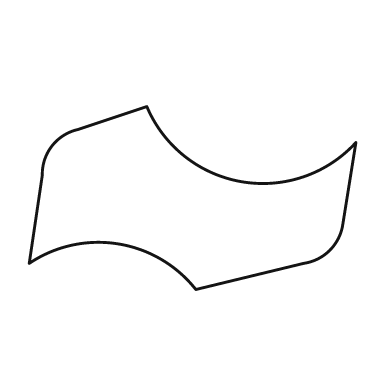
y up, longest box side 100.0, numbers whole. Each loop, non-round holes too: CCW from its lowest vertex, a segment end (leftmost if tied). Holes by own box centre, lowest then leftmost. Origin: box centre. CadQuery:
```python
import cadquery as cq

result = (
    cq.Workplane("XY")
    .moveTo(1.0, -28.0)
    .lineTo(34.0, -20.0)
    .threePointArc((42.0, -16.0), (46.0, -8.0))
    .lineTo(50.0, 17.0)
    .threePointArc((15.0, 5.0), (-14.0, 28.0))
    .lineTo(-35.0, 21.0)
    .threePointArc((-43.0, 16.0), (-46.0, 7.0))
    .lineTo(-50.0, -20.0)
    .threePointArc((-23.0, -14.0), (1.0, -28.0))
    .close()
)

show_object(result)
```